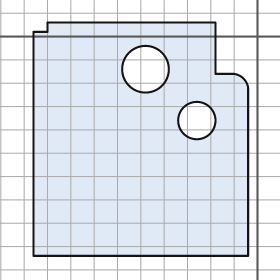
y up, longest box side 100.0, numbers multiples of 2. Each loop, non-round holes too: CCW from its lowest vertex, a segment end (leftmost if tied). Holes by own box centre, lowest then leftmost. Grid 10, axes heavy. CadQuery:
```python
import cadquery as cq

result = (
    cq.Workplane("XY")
    .moveTo(-96.0, -94.0)
    .lineTo(-4.0, -94.0)
    .lineTo(-4.0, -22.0)
    .threePointArc((-6.0, -18.0), (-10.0, -16.0))
    .lineTo(-18.0, -16.0)
    .lineTo(-18.0, 6.0)
    .lineTo(-90.0, 6.0)
    .lineTo(-90.0, 2.0)
    .lineTo(-96.0, 2.0)
    .close()
    .moveTo(-26.0, -36.0)
    .circle(8.0)
    .moveTo(-48.0, -14.0)
    .circle(10.0)
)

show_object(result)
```